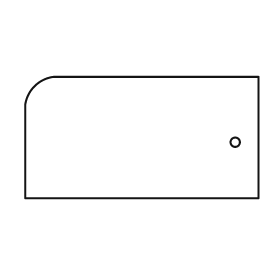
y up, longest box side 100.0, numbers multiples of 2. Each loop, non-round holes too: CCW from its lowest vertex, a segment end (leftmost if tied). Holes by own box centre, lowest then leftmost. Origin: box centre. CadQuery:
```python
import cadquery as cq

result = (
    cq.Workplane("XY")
    .moveTo(-50.0, -26.0)
    .lineTo(50.0, -26.0)
    .lineTo(50.0, 26.0)
    .lineTo(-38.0, 26.0)
    .threePointArc((-46.0, 22.0), (-50.0, 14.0))
    .close()
    .moveTo(40.0, -2.0)
    .circle(2.0)
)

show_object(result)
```